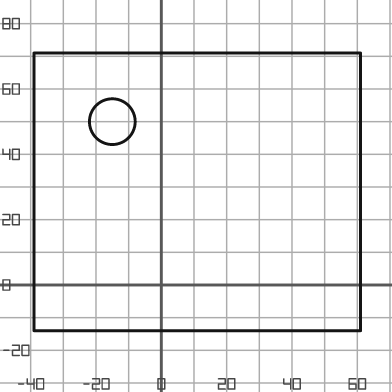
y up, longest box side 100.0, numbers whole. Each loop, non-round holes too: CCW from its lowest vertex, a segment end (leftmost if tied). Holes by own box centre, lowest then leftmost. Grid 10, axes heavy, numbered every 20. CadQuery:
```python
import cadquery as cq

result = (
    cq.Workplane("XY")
    .moveTo(-39.0, -14.0)
    .lineTo(61.0, -14.0)
    .lineTo(61.0, 71.0)
    .lineTo(-39.0, 71.0)
    .close()
    .moveTo(-15.0, 50.0)
    .circle(7.0)
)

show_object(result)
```